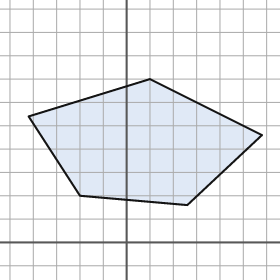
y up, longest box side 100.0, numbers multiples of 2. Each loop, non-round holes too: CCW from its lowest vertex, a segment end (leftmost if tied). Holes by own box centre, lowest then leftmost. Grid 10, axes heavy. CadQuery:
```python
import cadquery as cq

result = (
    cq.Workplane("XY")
    .moveTo(26.0, 16.0)
    .lineTo(58.0, 46.0)
    .lineTo(10.0, 70.0)
    .lineTo(-42.0, 54.0)
    .lineTo(-20.0, 20.0)
    .close()
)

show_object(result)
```